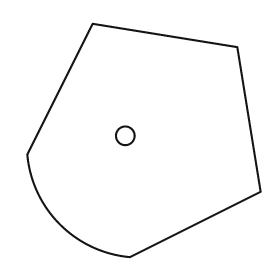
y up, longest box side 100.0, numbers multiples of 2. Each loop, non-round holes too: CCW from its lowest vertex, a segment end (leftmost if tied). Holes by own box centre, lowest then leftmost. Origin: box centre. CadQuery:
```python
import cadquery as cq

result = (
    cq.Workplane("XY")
    .moveTo(-6.0, -50.0)
    .lineTo(50.0, -22.0)
    .lineTo(40.0, 40.0)
    .lineTo(-22.0, 50.0)
    .lineTo(-50.0, -6.0)
    .threePointArc((-36.0, -36.0), (-6.0, -50.0))
    .close()
    .moveTo(-8.0, 2.0)
    .circle(4.0)
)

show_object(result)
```